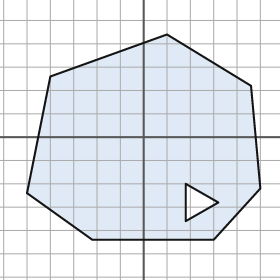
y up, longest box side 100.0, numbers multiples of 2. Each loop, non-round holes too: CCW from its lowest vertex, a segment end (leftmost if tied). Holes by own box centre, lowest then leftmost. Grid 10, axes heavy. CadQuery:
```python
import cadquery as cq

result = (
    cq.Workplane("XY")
    .moveTo(-22.0, -44.0)
    .lineTo(30.0, -44.0)
    .lineTo(50.0, -22.0)
    .lineTo(46.0, 22.0)
    .lineTo(10.0, 44.0)
    .lineTo(-40.0, 26.0)
    .lineTo(-50.0, -24.0)
    .close()
    .moveTo(18.0, -36.0)
    .lineTo(32.0, -28.0)
    .lineTo(18.0, -20.0)
    .close()
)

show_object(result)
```